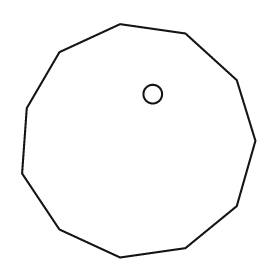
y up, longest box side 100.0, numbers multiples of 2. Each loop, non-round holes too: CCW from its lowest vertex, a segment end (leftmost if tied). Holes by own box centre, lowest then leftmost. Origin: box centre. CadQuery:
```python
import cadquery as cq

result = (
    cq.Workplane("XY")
    .moveTo(-8.0, -50.0)
    .lineTo(20.0, -46.0)
    .lineTo(42.0, -28.0)
    .lineTo(50.0, 0.0)
    .lineTo(42.0, 26.0)
    .lineTo(20.0, 46.0)
    .lineTo(-8.0, 50.0)
    .lineTo(-34.0, 38.0)
    .lineTo(-48.0, 14.0)
    .lineTo(-50.0, -14.0)
    .lineTo(-34.0, -38.0)
    .close()
    .moveTo(6.0, 20.0)
    .circle(4.0)
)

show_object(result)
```